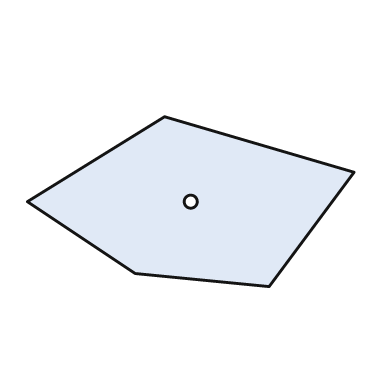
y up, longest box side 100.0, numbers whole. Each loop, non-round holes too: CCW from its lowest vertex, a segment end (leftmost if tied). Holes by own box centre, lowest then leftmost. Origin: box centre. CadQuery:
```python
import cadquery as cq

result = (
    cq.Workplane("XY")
    .moveTo(24.0, -26.0)
    .lineTo(50.0, 9.0)
    .lineTo(-8.0, 26.0)
    .lineTo(-50.0, 0.0)
    .lineTo(-17.0, -22.0)
    .close()
    .moveTo(0.0, 0.0)
    .circle(2.0)
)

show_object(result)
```